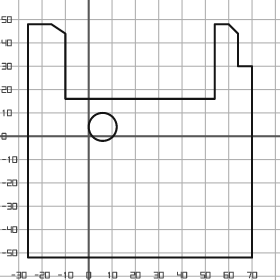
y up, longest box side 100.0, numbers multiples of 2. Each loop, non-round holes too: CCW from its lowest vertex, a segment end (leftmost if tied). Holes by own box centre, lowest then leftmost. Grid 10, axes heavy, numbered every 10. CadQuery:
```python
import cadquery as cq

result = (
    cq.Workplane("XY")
    .moveTo(-26.0, -52.0)
    .lineTo(70.0, -52.0)
    .lineTo(70.0, 30.0)
    .lineTo(64.0, 30.0)
    .lineTo(64.0, 44.0)
    .lineTo(60.0, 48.0)
    .lineTo(54.0, 48.0)
    .lineTo(54.0, 16.0)
    .lineTo(-10.0, 16.0)
    .lineTo(-10.0, 44.0)
    .lineTo(-16.0, 48.0)
    .lineTo(-26.0, 48.0)
    .close()
    .moveTo(6.0, 4.0)
    .circle(6.0)
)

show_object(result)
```